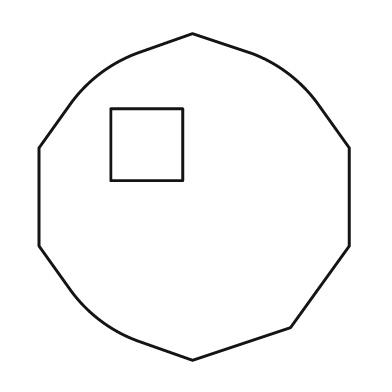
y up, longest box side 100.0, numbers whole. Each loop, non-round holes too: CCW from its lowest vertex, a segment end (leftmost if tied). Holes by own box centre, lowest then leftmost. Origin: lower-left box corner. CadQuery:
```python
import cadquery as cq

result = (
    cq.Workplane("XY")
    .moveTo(47.0, 0.0)
    .lineTo(77.0, 10.0)
    .lineTo(95.0, 35.0)
    .lineTo(95.0, 65.0)
    .lineTo(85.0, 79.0)
    .threePointArc((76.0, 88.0), (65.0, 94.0))
    .lineTo(47.0, 100.0)
    .lineTo(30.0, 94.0)
    .threePointArc((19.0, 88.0), (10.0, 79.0))
    .lineTo(0.0, 65.0)
    .lineTo(0.0, 35.0)
    .lineTo(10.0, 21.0)
    .threePointArc((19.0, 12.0), (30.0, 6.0))
    .close()
    .moveTo(22.0, 55.0)
    .lineTo(44.0, 55.0)
    .lineTo(44.0, 77.0)
    .lineTo(22.0, 77.0)
    .close()
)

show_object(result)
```